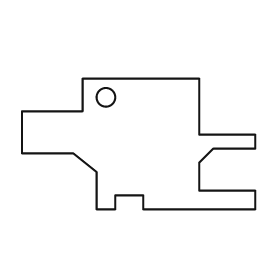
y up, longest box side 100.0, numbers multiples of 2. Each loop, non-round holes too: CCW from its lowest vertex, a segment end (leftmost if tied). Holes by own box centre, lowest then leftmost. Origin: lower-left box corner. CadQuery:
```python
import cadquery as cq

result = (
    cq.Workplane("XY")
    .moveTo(32.0, 0.0)
    .lineTo(40.0, 0.0)
    .lineTo(40.0, 6.0)
    .lineTo(52.0, 6.0)
    .lineTo(52.0, 0.0)
    .lineTo(100.0, 0.0)
    .lineTo(100.0, 8.0)
    .lineTo(76.0, 8.0)
    .lineTo(76.0, 20.0)
    .lineTo(82.0, 26.0)
    .lineTo(100.0, 26.0)
    .lineTo(100.0, 32.0)
    .lineTo(76.0, 32.0)
    .lineTo(76.0, 56.0)
    .lineTo(26.0, 56.0)
    .lineTo(26.0, 42.0)
    .lineTo(0.0, 42.0)
    .lineTo(0.0, 24.0)
    .lineTo(22.0, 24.0)
    .lineTo(32.0, 16.0)
    .close()
    .moveTo(36.0, 48.0)
    .circle(4.0)
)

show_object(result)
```